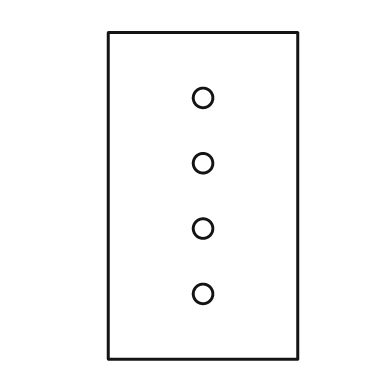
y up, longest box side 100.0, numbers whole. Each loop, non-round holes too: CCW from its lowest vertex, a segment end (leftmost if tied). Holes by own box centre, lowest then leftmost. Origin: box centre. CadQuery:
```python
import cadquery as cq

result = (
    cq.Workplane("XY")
    .moveTo(-29.0, -50.0)
    .lineTo(29.0, -50.0)
    .lineTo(29.0, 50.0)
    .lineTo(-29.0, 50.0)
    .close()
    .moveTo(0.0, -30.0)
    .circle(3.0)
    .moveTo(0.0, -10.0)
    .circle(3.0)
    .moveTo(0.0, 10.0)
    .circle(3.0)
    .moveTo(0.0, 30.0)
    .circle(3.0)
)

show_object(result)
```